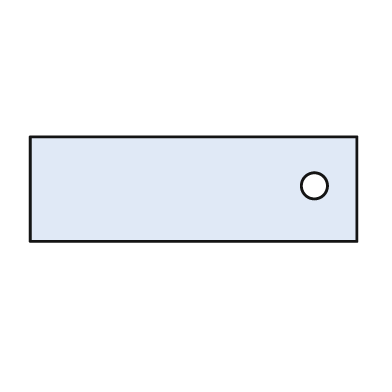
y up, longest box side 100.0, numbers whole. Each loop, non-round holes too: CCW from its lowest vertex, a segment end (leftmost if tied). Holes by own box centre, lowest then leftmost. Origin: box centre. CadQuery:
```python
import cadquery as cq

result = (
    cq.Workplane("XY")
    .moveTo(-50.0, -16.0)
    .lineTo(50.0, -16.0)
    .lineTo(50.0, 16.0)
    .lineTo(-50.0, 16.0)
    .close()
    .moveTo(37.0, 1.0)
    .circle(4.0)
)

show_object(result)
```